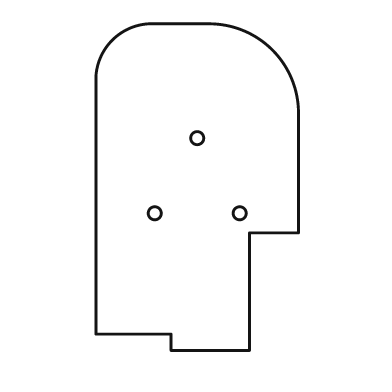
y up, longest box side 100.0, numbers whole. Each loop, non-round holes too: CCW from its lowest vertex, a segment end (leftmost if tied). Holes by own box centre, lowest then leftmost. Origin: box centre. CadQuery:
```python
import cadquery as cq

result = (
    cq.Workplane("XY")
    .moveTo(-8.0, -50.0)
    .lineTo(16.0, -50.0)
    .lineTo(16.0, -14.0)
    .lineTo(31.0, -14.0)
    .lineTo(31.0, 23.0)
    .threePointArc((23.0, 42.0), (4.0, 50.0))
    .lineTo(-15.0, 50.0)
    .threePointArc((-26.0, 45.0), (-31.0, 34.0))
    .lineTo(-31.0, -45.0)
    .lineTo(-8.0, -45.0)
    .close()
    .moveTo(-13.0, -8.0)
    .circle(2.0)
    .moveTo(13.0, -8.0)
    .circle(2.0)
    .moveTo(0.0, 15.0)
    .circle(2.0)
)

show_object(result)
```